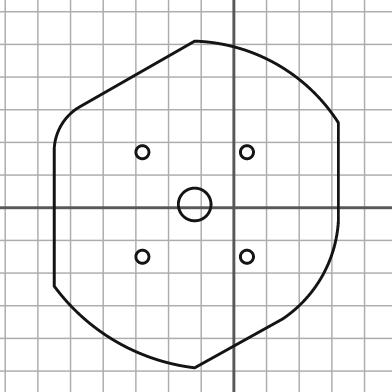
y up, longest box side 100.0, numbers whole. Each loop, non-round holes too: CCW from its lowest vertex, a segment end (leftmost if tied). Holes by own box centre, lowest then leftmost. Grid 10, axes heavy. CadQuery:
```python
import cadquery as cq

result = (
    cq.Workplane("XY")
    .moveTo(-12.0, -49.0)
    .lineTo(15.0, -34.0)
    .threePointArc((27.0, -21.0), (32.0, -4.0))
    .lineTo(32.0, 26.0)
    .threePointArc((13.0, 44.0), (-12.0, 51.0))
    .lineTo(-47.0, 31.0)
    .threePointArc((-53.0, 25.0), (-55.0, 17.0))
    .lineTo(-55.0, -24.0)
    .threePointArc((-36.0, -41.0), (-12.0, -49.0))
    .close()
    .moveTo(-28.0, -15.0)
    .circle(2.0)
    .moveTo(4.0, -15.0)
    .circle(2.0)
    .moveTo(-12.0, 1.0)
    .circle(5.0)
    .moveTo(-28.0, 17.0)
    .circle(2.0)
    .moveTo(4.0, 17.0)
    .circle(2.0)
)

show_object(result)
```